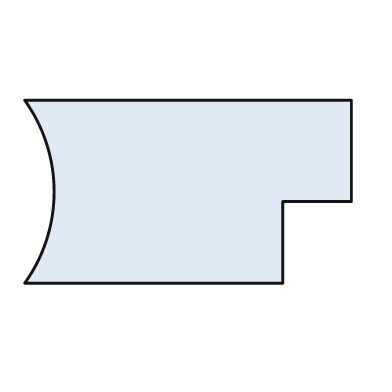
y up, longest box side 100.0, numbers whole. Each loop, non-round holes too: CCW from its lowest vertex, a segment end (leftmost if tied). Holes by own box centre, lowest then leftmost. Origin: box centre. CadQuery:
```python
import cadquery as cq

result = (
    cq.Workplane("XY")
    .moveTo(-50.0, -28.0)
    .lineTo(29.0, -28.0)
    .lineTo(29.0, -3.0)
    .lineTo(50.0, -3.0)
    .lineTo(50.0, 28.0)
    .lineTo(-50.0, 28.0)
    .threePointArc((-41.0, 0.0), (-50.0, -28.0))
    .close()
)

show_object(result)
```